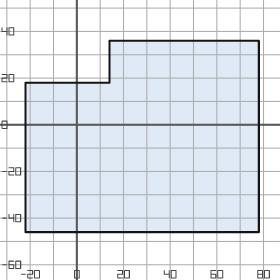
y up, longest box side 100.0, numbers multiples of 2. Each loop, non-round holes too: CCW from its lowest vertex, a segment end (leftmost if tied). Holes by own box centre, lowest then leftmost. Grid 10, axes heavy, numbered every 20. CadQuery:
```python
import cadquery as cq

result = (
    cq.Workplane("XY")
    .moveTo(-22.0, -46.0)
    .lineTo(78.0, -46.0)
    .lineTo(78.0, 36.0)
    .lineTo(14.0, 36.0)
    .lineTo(14.0, 18.0)
    .lineTo(-22.0, 18.0)
    .close()
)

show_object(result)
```